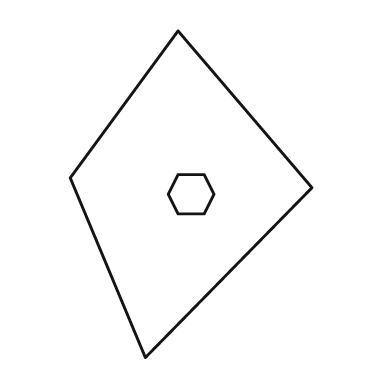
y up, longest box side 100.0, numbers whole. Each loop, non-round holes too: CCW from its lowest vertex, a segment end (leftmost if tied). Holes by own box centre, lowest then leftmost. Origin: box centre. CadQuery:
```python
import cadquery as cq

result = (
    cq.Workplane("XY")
    .moveTo(-14.0, -50.0)
    .lineTo(37.0, 2.0)
    .lineTo(-4.0, 50.0)
    .lineTo(-37.0, 5.0)
    .close()
    .moveTo(-4.0, -6.0)
    .lineTo(4.0, -6.0)
    .lineTo(7.0, 0.0)
    .lineTo(4.0, 6.0)
    .lineTo(-4.0, 6.0)
    .lineTo(-7.0, 0.0)
    .close()
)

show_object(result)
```